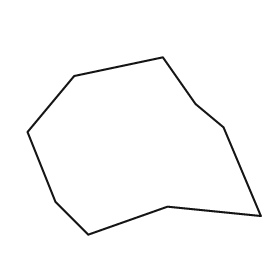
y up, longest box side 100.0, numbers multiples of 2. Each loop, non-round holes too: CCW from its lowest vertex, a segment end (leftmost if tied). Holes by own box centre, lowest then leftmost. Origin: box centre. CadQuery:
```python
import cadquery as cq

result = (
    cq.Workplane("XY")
    .moveTo(-24.0, -38.0)
    .lineTo(10.0, -26.0)
    .lineTo(50.0, -30.0)
    .lineTo(34.0, 8.0)
    .lineTo(22.0, 18.0)
    .lineTo(8.0, 38.0)
    .lineTo(-30.0, 30.0)
    .lineTo(-50.0, 6.0)
    .lineTo(-38.0, -24.0)
    .close()
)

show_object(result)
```